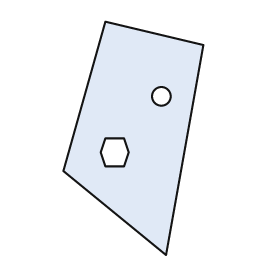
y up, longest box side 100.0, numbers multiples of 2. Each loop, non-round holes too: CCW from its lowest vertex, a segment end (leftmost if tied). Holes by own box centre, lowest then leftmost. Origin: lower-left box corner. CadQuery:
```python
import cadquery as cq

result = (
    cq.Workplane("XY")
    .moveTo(44.0, 0.0)
    .lineTo(60.0, 90.0)
    .lineTo(18.0, 100.0)
    .lineTo(0.0, 36.0)
    .close()
    .moveTo(18.0, 38.0)
    .lineTo(26.0, 38.0)
    .lineTo(28.0, 44.0)
    .lineTo(26.0, 50.0)
    .lineTo(18.0, 50.0)
    .lineTo(16.0, 44.0)
    .close()
    .moveTo(42.0, 68.0)
    .circle(4.0)
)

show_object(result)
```